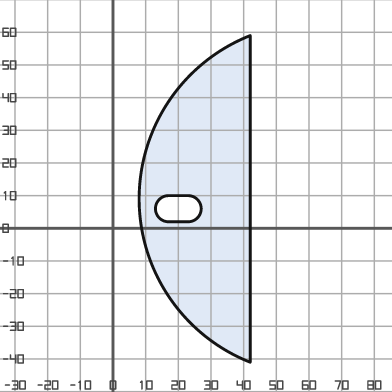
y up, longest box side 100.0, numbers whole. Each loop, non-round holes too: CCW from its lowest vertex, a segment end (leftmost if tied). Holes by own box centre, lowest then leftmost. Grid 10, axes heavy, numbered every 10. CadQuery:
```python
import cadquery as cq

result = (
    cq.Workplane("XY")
    .moveTo(42.0, -41.0)
    .lineTo(42.0, 59.0)
    .threePointArc((8.0, 9.0), (42.0, -41.0))
    .close()
    .moveTo(17.0, 2.0)
    .lineTo(23.0, 2.0)
    .threePointArc((27.0, 6.0), (23.0, 10.0))
    .lineTo(17.0, 10.0)
    .threePointArc((13.0, 6.0), (17.0, 2.0))
    .close()
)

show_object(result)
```